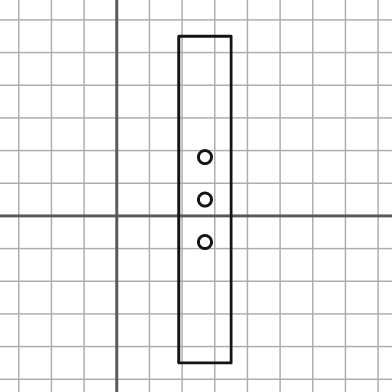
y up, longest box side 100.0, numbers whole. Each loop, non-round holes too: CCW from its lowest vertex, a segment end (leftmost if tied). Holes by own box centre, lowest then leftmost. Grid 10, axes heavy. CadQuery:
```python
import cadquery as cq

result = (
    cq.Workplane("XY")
    .moveTo(19.0, -45.0)
    .lineTo(35.0, -45.0)
    .lineTo(35.0, 55.0)
    .lineTo(19.0, 55.0)
    .close()
    .moveTo(27.0, -8.0)
    .circle(2.0)
    .moveTo(27.0, 5.0)
    .circle(2.0)
    .moveTo(27.0, 18.0)
    .circle(2.0)
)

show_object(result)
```